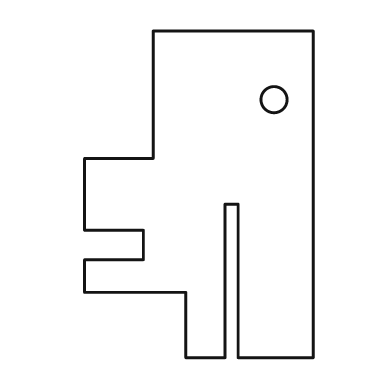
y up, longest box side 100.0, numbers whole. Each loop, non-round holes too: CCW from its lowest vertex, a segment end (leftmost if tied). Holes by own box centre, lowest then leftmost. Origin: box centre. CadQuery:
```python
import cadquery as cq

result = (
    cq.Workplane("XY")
    .moveTo(-4.0, -50.0)
    .lineTo(8.0, -50.0)
    .lineTo(8.0, -3.0)
    .lineTo(12.0, -3.0)
    .lineTo(12.0, -50.0)
    .lineTo(35.0, -50.0)
    .lineTo(35.0, 50.0)
    .lineTo(-14.0, 50.0)
    .lineTo(-14.0, 11.0)
    .lineTo(-35.0, 11.0)
    .lineTo(-35.0, -11.0)
    .lineTo(-17.0, -11.0)
    .lineTo(-17.0, -20.0)
    .lineTo(-35.0, -20.0)
    .lineTo(-35.0, -30.0)
    .lineTo(-4.0, -30.0)
    .close()
    .moveTo(23.0, 29.0)
    .circle(4.0)
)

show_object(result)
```